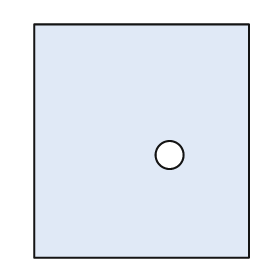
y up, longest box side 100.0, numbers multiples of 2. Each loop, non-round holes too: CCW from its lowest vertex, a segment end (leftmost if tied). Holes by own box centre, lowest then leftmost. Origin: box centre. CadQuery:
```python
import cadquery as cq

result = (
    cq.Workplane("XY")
    .moveTo(-46.0, -50.0)
    .lineTo(46.0, -50.0)
    .lineTo(46.0, 50.0)
    .lineTo(-46.0, 50.0)
    .close()
    .moveTo(12.0, -6.0)
    .circle(6.0)
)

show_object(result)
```